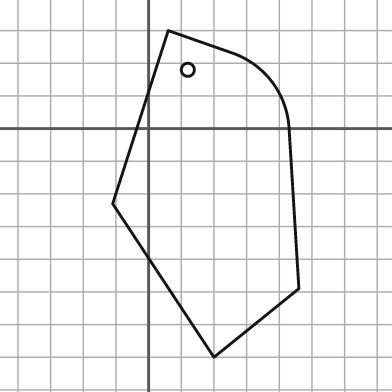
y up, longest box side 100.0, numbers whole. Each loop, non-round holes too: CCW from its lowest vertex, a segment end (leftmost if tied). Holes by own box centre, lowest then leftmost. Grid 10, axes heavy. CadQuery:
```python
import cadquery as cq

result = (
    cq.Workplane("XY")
    .moveTo(20.0, -70.0)
    .lineTo(46.0, -49.0)
    .lineTo(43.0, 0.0)
    .threePointArc((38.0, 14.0), (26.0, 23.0))
    .lineTo(6.0, 30.0)
    .lineTo(-11.0, -23.0)
    .close()
    .moveTo(12.0, 18.0)
    .circle(2.0)
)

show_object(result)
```